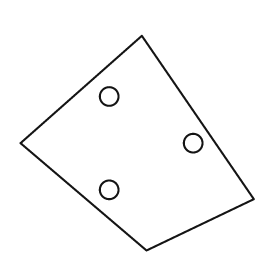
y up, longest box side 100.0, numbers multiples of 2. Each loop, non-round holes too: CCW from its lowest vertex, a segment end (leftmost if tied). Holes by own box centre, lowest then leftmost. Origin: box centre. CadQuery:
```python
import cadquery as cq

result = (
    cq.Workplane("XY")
    .moveTo(4.0, -46.0)
    .lineTo(50.0, -24.0)
    .lineTo(2.0, 46.0)
    .lineTo(-50.0, 0.0)
    .close()
    .moveTo(-12.0, -20.0)
    .circle(4.0)
    .moveTo(24.0, 0.0)
    .circle(4.0)
    .moveTo(-12.0, 20.0)
    .circle(4.0)
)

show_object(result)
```